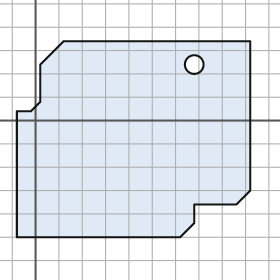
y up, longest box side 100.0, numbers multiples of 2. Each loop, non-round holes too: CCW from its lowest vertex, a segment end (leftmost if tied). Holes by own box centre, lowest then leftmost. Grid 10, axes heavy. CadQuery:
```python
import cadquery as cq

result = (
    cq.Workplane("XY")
    .moveTo(-8.0, -50.0)
    .lineTo(62.0, -50.0)
    .lineTo(68.0, -44.0)
    .lineTo(68.0, -36.0)
    .lineTo(86.0, -36.0)
    .lineTo(92.0, -30.0)
    .lineTo(92.0, 34.0)
    .lineTo(12.0, 34.0)
    .lineTo(2.0, 24.0)
    .lineTo(2.0, 8.0)
    .lineTo(-2.0, 4.0)
    .lineTo(-8.0, 4.0)
    .close()
    .moveTo(68.0, 24.0)
    .circle(4.0)
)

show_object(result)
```